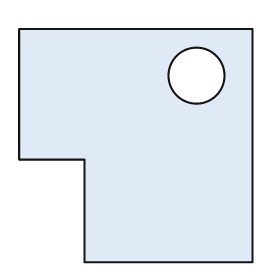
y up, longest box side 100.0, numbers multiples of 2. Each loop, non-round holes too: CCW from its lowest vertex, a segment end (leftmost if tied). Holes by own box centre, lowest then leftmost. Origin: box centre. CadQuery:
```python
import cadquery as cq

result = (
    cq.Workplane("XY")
    .moveTo(-22.0, -50.0)
    .lineTo(50.0, -50.0)
    .lineTo(50.0, 50.0)
    .lineTo(-50.0, 50.0)
    .lineTo(-50.0, -6.0)
    .lineTo(-22.0, -6.0)
    .close()
    .moveTo(26.0, 30.0)
    .circle(12.0)
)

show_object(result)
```